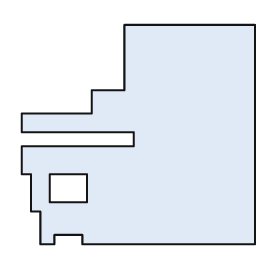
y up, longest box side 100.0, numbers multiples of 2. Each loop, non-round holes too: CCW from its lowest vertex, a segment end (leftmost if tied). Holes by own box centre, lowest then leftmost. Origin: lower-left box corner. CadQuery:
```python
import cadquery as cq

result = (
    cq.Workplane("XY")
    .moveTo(8.0, 0.0)
    .lineTo(14.0, 0.0)
    .lineTo(14.0, 4.0)
    .lineTo(26.0, 4.0)
    .lineTo(26.0, 0.0)
    .lineTo(100.0, 0.0)
    .lineTo(100.0, 94.0)
    .lineTo(44.0, 94.0)
    .lineTo(44.0, 66.0)
    .lineTo(30.0, 66.0)
    .lineTo(30.0, 56.0)
    .lineTo(0.0, 56.0)
    .lineTo(0.0, 48.0)
    .lineTo(48.0, 48.0)
    .lineTo(48.0, 42.0)
    .lineTo(0.0, 42.0)
    .lineTo(0.0, 30.0)
    .lineTo(4.0, 30.0)
    .lineTo(4.0, 14.0)
    .lineTo(8.0, 14.0)
    .close()
    .moveTo(12.0, 18.0)
    .lineTo(28.0, 18.0)
    .lineTo(28.0, 30.0)
    .lineTo(12.0, 30.0)
    .close()
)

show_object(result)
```